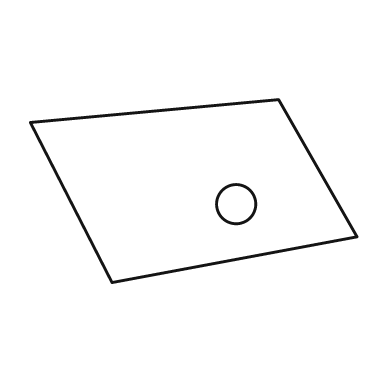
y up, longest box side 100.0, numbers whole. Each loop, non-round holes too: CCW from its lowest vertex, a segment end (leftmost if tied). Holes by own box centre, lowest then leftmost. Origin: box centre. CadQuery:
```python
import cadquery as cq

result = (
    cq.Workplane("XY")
    .moveTo(-25.0, -28.0)
    .lineTo(50.0, -14.0)
    .lineTo(26.0, 28.0)
    .lineTo(-50.0, 21.0)
    .close()
    .moveTo(13.0, -4.0)
    .circle(6.0)
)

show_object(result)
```